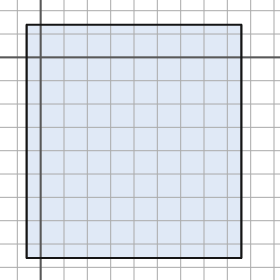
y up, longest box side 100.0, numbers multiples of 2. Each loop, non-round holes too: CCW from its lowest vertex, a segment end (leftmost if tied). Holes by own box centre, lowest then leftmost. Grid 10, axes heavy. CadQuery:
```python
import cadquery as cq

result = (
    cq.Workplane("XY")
    .moveTo(-6.0, -86.0)
    .lineTo(86.0, -86.0)
    .lineTo(86.0, 14.0)
    .lineTo(-6.0, 14.0)
    .close()
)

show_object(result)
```